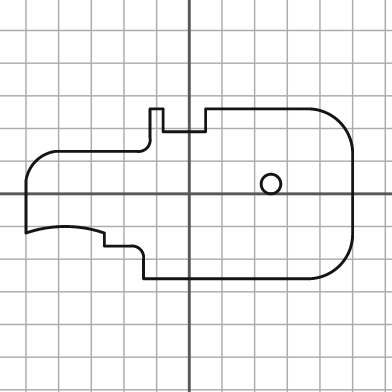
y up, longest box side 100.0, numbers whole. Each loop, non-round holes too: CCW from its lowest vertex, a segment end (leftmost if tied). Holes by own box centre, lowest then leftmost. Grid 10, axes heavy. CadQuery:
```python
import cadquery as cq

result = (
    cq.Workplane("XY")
    .moveTo(-14.0, -26.0)
    .lineTo(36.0, -26.0)
    .threePointArc((46.0, -22.0), (50.0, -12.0))
    .lineTo(50.0, 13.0)
    .threePointArc((46.0, 22.0), (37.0, 26.0))
    .lineTo(5.0, 26.0)
    .lineTo(5.0, 19.0)
    .lineTo(-8.0, 19.0)
    .lineTo(-8.0, 26.0)
    .lineTo(-12.0, 26.0)
    .lineTo(-12.0, 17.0)
    .threePointArc((-13.0, 14.0), (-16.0, 13.0))
    .lineTo(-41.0, 13.0)
    .threePointArc((-47.0, 10.0), (-50.0, 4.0))
    .lineTo(-50.0, -12.0)
    .threePointArc((-38.0, -10.0), (-26.0, -12.0))
    .lineTo(-26.0, -16.0)
    .lineTo(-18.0, -16.0)
    .threePointArc((-15.0, -17.0), (-14.0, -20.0))
    .close()
    .moveTo(25.0, 3.0)
    .circle(3.0)
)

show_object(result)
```